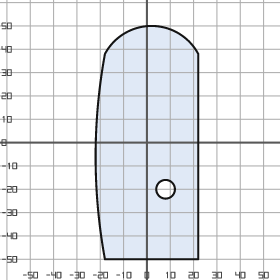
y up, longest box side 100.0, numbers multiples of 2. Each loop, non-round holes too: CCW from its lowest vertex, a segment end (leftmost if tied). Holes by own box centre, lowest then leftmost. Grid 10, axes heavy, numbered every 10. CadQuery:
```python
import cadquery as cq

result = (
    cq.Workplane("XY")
    .moveTo(-18.0, -50.0)
    .lineTo(22.0, -50.0)
    .lineTo(22.0, 38.0)
    .threePointArc((2.0, 50.0), (-18.0, 38.0))
    .threePointArc((-22.0, -6.0), (-18.0, -50.0))
    .close()
    .moveTo(8.0, -20.0)
    .circle(4.0)
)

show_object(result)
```